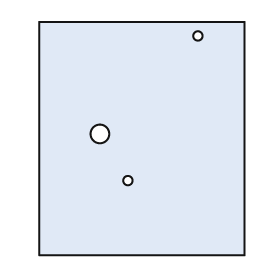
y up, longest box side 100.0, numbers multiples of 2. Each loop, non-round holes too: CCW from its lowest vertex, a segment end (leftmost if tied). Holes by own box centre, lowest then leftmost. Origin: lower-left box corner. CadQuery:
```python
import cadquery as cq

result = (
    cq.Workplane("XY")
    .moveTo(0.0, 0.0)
    .lineTo(88.0, 0.0)
    .lineTo(88.0, 100.0)
    .lineTo(0.0, 100.0)
    .close()
    .moveTo(38.0, 32.0)
    .circle(2.0)
    .moveTo(26.0, 52.0)
    .circle(4.0)
    .moveTo(68.0, 94.0)
    .circle(2.0)
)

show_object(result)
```